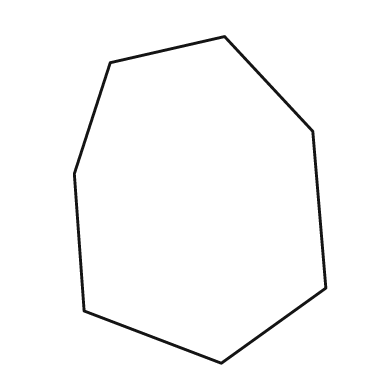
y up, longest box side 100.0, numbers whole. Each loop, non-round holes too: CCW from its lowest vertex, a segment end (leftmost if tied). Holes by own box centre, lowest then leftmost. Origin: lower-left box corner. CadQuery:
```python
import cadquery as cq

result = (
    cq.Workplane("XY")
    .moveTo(45.0, 0.0)
    .lineTo(77.0, 23.0)
    .lineTo(73.0, 71.0)
    .lineTo(46.0, 100.0)
    .lineTo(11.0, 92.0)
    .lineTo(0.0, 58.0)
    .lineTo(3.0, 16.0)
    .close()
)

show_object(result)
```